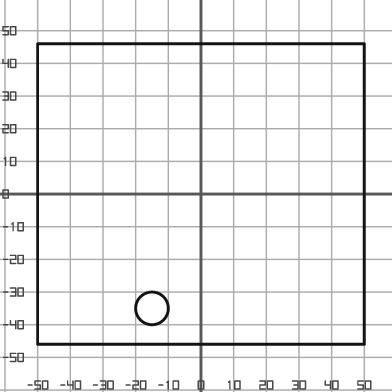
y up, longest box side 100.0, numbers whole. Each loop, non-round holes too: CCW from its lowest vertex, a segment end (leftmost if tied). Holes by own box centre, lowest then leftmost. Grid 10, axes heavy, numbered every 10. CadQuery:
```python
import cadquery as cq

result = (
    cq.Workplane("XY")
    .moveTo(-50.0, -46.0)
    .lineTo(50.0, -46.0)
    .lineTo(50.0, 46.0)
    .lineTo(-50.0, 46.0)
    .close()
    .moveTo(-15.0, -35.0)
    .circle(5.0)
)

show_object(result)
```